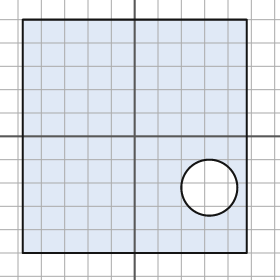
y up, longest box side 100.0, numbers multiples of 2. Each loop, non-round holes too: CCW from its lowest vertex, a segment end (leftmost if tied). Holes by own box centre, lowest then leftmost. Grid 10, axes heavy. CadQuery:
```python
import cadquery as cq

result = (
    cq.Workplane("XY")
    .moveTo(-48.0, -50.0)
    .lineTo(48.0, -50.0)
    .lineTo(48.0, 50.0)
    .lineTo(-48.0, 50.0)
    .close()
    .moveTo(32.0, -22.0)
    .circle(12.0)
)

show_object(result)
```